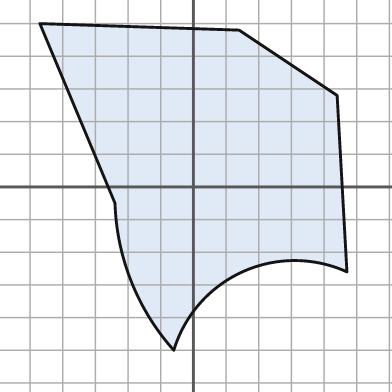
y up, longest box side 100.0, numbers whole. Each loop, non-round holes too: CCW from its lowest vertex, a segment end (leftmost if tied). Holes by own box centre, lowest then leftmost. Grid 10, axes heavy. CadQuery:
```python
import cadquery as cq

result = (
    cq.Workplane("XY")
    .moveTo(-6.0, -50.0)
    .threePointArc((15.0, -26.0), (47.0, -26.0))
    .lineTo(44.0, 28.0)
    .lineTo(14.0, 48.0)
    .lineTo(-47.0, 50.0)
    .lineTo(-24.0, -5.0)
    .threePointArc((-19.0, -29.0), (-6.0, -50.0))
    .close()
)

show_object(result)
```